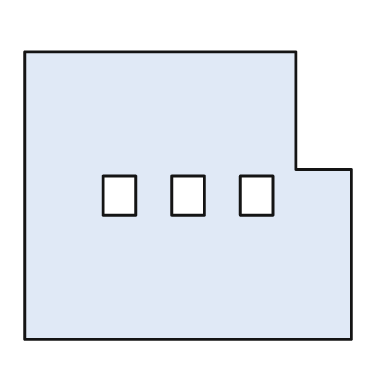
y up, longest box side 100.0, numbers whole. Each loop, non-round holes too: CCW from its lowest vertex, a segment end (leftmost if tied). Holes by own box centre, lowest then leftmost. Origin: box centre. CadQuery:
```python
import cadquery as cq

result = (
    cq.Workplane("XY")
    .moveTo(-50.0, -44.0)
    .lineTo(50.0, -44.0)
    .lineTo(50.0, 8.0)
    .lineTo(33.0, 8.0)
    .lineTo(33.0, 44.0)
    .lineTo(-50.0, 44.0)
    .close()
    .moveTo(-26.0, -6.0)
    .lineTo(-16.0, -6.0)
    .lineTo(-16.0, 6.0)
    .lineTo(-26.0, 6.0)
    .close()
    .moveTo(-5.0, -6.0)
    .lineTo(5.0, -6.0)
    .lineTo(5.0, 6.0)
    .lineTo(-5.0, 6.0)
    .close()
    .moveTo(16.0, -6.0)
    .lineTo(26.0, -6.0)
    .lineTo(26.0, 6.0)
    .lineTo(16.0, 6.0)
    .close()
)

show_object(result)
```